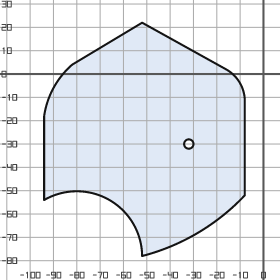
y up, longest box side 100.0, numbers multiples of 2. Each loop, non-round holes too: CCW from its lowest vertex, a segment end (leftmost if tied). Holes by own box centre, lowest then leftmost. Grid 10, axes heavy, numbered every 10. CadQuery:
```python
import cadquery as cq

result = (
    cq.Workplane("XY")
    .moveTo(-52.0, -78.0)
    .threePointArc((-28.0, -68.0), (-8.0, -52.0))
    .lineTo(-8.0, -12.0)
    .threePointArc((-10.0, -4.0), (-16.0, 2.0))
    .lineTo(-52.0, 22.0)
    .lineTo(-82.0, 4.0)
    .threePointArc((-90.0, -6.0), (-94.0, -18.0))
    .lineTo(-94.0, -54.0)
    .threePointArc((-66.0, -54.0), (-52.0, -78.0))
    .close()
    .moveTo(-32.0, -30.0)
    .circle(2.0)
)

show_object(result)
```